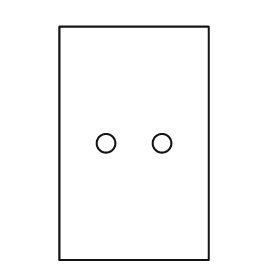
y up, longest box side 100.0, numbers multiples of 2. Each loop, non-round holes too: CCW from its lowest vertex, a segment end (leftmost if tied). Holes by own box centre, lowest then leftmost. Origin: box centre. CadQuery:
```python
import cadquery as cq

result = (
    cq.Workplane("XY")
    .moveTo(-32.0, -50.0)
    .lineTo(32.0, -50.0)
    .lineTo(32.0, 50.0)
    .lineTo(-32.0, 50.0)
    .close()
    .moveTo(-12.0, 0.0)
    .circle(4.0)
    .moveTo(12.0, 0.0)
    .circle(4.0)
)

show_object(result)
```